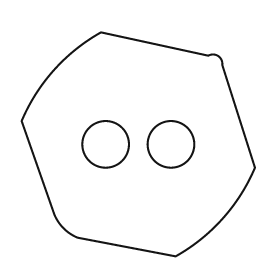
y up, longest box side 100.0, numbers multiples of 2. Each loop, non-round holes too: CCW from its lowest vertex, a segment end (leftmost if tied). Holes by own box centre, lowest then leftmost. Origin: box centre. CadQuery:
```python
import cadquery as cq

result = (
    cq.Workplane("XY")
    .moveTo(16.0, -48.0)
    .threePointArc((36.0, -32.0), (50.0, -10.0))
    .lineTo(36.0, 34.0)
    .threePointArc((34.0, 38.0), (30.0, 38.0))
    .lineTo(-16.0, 48.0)
    .threePointArc((-36.0, 32.0), (-50.0, 10.0))
    .lineTo(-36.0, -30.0)
    .threePointArc((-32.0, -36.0), (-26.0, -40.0))
    .close()
    .moveTo(-14.0, 0.0)
    .circle(10.0)
    .moveTo(14.0, 0.0)
    .circle(10.0)
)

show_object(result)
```